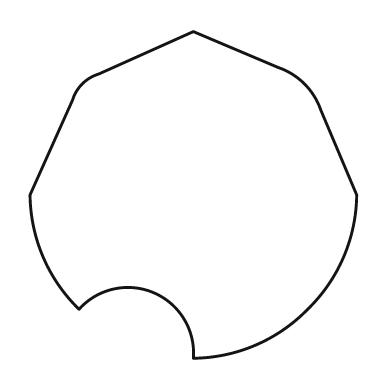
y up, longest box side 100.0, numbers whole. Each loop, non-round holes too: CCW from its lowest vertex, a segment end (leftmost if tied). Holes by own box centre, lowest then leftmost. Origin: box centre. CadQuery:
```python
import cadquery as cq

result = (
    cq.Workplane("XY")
    .moveTo(0.0, -50.0)
    .threePointArc((19.0, -46.0), (35.0, -35.0))
    .threePointArc((46.0, -19.0), (50.0, 0.0))
    .lineTo(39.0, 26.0)
    .threePointArc((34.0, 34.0), (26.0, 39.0))
    .lineTo(0.0, 50.0)
    .lineTo(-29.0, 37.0)
    .threePointArc((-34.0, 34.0), (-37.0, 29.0))
    .lineTo(-50.0, 0.0)
    .threePointArc((-46.0, -19.0), (-35.0, -35.0))
    .threePointArc((-12.0, -30.0), (0.0, -50.0))
    .close()
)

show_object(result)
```